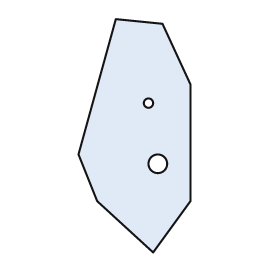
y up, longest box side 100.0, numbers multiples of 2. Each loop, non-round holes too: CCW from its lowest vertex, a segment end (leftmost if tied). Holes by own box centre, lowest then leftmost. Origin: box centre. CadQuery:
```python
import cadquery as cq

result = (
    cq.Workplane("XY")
    .moveTo(8.0, -50.0)
    .lineTo(24.0, -28.0)
    .lineTo(24.0, 22.0)
    .lineTo(12.0, 48.0)
    .lineTo(-8.0, 50.0)
    .lineTo(-24.0, -8.0)
    .lineTo(-16.0, -28.0)
    .close()
    .moveTo(10.0, -12.0)
    .circle(4.0)
    .moveTo(6.0, 14.0)
    .circle(2.0)
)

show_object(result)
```